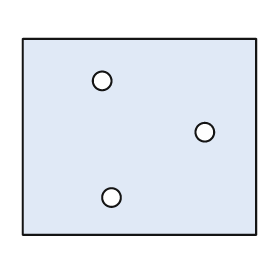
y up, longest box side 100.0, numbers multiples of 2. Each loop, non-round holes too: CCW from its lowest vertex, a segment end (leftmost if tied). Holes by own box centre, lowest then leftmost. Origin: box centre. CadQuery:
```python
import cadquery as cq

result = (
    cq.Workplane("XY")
    .moveTo(-50.0, -42.0)
    .lineTo(50.0, -42.0)
    .lineTo(50.0, 42.0)
    .lineTo(-50.0, 42.0)
    .close()
    .moveTo(-12.0, -26.0)
    .circle(4.0)
    .moveTo(28.0, 2.0)
    .circle(4.0)
    .moveTo(-16.0, 24.0)
    .circle(4.0)
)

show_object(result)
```